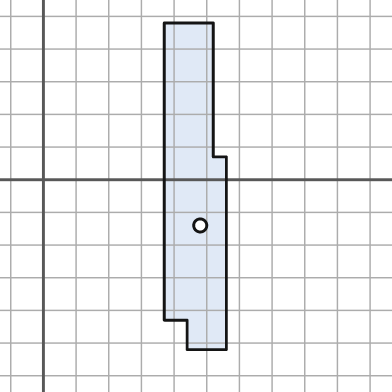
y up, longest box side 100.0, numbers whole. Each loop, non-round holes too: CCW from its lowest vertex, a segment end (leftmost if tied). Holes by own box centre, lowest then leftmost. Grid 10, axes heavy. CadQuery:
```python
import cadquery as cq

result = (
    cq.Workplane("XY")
    .moveTo(44.0, -52.0)
    .lineTo(56.0, -52.0)
    .lineTo(56.0, 7.0)
    .lineTo(52.0, 7.0)
    .lineTo(52.0, 48.0)
    .lineTo(37.0, 48.0)
    .lineTo(37.0, -43.0)
    .lineTo(44.0, -43.0)
    .close()
    .moveTo(48.0, -14.0)
    .circle(2.0)
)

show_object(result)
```